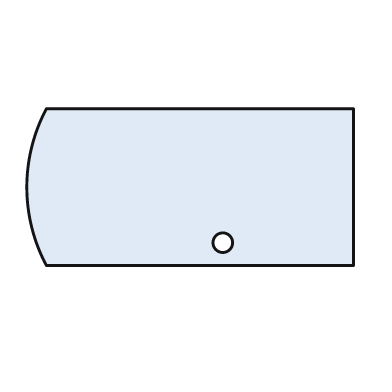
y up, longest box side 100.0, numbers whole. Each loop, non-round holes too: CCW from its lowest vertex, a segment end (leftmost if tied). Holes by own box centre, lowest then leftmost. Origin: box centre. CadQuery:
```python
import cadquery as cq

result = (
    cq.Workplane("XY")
    .moveTo(-44.0, -24.0)
    .lineTo(50.0, -24.0)
    .lineTo(50.0, 24.0)
    .lineTo(-44.0, 24.0)
    .threePointArc((-50.0, 0.0), (-44.0, -24.0))
    .close()
    .moveTo(10.0, -17.0)
    .circle(3.0)
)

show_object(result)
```